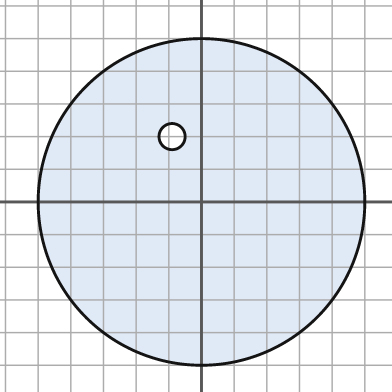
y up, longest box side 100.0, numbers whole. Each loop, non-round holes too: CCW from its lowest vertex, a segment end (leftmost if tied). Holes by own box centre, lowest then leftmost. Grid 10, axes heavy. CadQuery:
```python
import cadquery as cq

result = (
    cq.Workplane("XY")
    .moveTo(0.0, 0.0)
    .circle(50.0)
    .moveTo(-9.0, 20.0)
    .circle(4.0)
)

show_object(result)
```